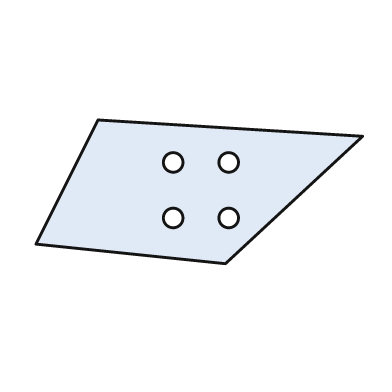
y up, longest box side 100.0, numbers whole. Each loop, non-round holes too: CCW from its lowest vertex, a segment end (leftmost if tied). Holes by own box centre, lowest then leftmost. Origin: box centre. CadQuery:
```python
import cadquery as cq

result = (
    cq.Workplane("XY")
    .moveTo(8.0, -22.0)
    .lineTo(50.0, 17.0)
    .lineTo(-31.0, 22.0)
    .lineTo(-50.0, -16.0)
    .close()
    .moveTo(-8.0, -8.0)
    .circle(3.0)
    .moveTo(9.0, -8.0)
    .circle(3.0)
    .moveTo(-8.0, 9.0)
    .circle(3.0)
    .moveTo(9.0, 9.0)
    .circle(3.0)
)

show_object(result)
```